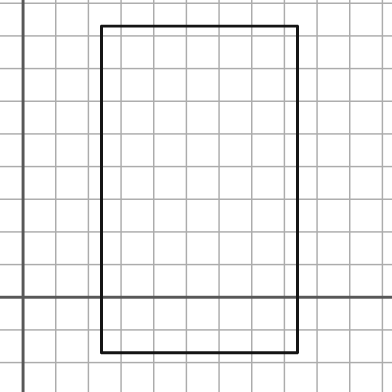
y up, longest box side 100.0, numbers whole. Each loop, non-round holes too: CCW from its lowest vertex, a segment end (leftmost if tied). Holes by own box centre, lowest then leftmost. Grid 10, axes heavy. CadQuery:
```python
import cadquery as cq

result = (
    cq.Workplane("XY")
    .moveTo(24.0, -17.0)
    .lineTo(84.0, -17.0)
    .lineTo(84.0, 83.0)
    .lineTo(24.0, 83.0)
    .close()
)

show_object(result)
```